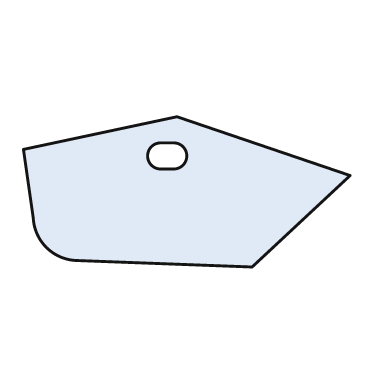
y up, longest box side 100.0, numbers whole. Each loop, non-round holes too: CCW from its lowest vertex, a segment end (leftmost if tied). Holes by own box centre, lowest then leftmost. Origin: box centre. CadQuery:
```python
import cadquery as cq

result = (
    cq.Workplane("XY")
    .moveTo(20.0, -23.0)
    .lineTo(50.0, 5.0)
    .lineTo(-3.0, 23.0)
    .lineTo(-50.0, 13.0)
    .lineTo(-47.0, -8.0)
    .threePointArc((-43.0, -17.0), (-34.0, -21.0))
    .close()
    .moveTo(-8.0, 7.0)
    .lineTo(-4.0, 7.0)
    .threePointArc((0.0, 11.0), (-4.0, 15.0))
    .lineTo(-8.0, 15.0)
    .threePointArc((-12.0, 11.0), (-8.0, 7.0))
    .close()
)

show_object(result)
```